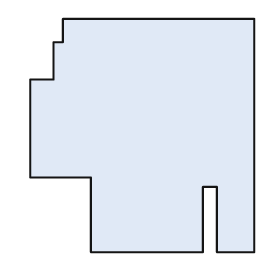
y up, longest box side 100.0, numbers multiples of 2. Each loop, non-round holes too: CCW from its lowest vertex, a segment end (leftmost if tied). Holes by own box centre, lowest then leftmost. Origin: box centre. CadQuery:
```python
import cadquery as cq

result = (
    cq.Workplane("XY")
    .moveTo(-22.0, -50.0)
    .lineTo(26.0, -50.0)
    .lineTo(26.0, -22.0)
    .lineTo(32.0, -22.0)
    .lineTo(32.0, -50.0)
    .lineTo(48.0, -50.0)
    .lineTo(48.0, 50.0)
    .lineTo(-34.0, 50.0)
    .lineTo(-34.0, 40.0)
    .lineTo(-38.0, 40.0)
    .lineTo(-38.0, 24.0)
    .lineTo(-48.0, 24.0)
    .lineTo(-48.0, -18.0)
    .lineTo(-22.0, -18.0)
    .close()
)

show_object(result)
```